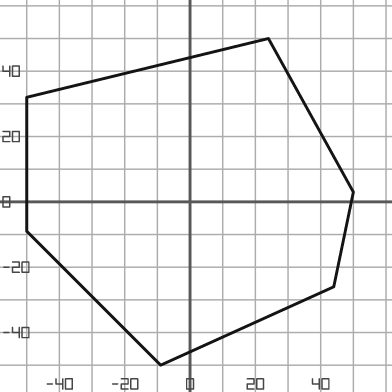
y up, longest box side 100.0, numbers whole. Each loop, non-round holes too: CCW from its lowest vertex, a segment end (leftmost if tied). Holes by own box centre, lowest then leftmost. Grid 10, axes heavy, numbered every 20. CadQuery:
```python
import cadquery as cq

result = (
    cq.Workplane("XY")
    .moveTo(-9.0, -50.0)
    .lineTo(44.0, -26.0)
    .lineTo(50.0, 3.0)
    .lineTo(24.0, 50.0)
    .lineTo(-50.0, 32.0)
    .lineTo(-50.0, -9.0)
    .close()
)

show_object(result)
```